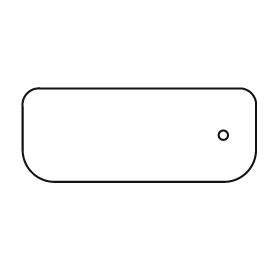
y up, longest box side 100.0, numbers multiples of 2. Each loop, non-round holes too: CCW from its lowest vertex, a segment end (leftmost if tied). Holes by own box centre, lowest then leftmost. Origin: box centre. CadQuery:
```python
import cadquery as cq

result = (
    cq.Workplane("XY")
    .moveTo(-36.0, -20.0)
    .lineTo(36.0, -20.0)
    .threePointArc((46.0, -16.0), (50.0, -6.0))
    .lineTo(50.0, 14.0)
    .threePointArc((48.0, 18.0), (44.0, 20.0))
    .lineTo(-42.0, 20.0)
    .threePointArc((-48.0, 18.0), (-50.0, 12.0))
    .lineTo(-50.0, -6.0)
    .threePointArc((-46.0, -16.0), (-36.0, -20.0))
    .close()
    .moveTo(36.0, 0.0)
    .circle(2.0)
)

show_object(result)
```